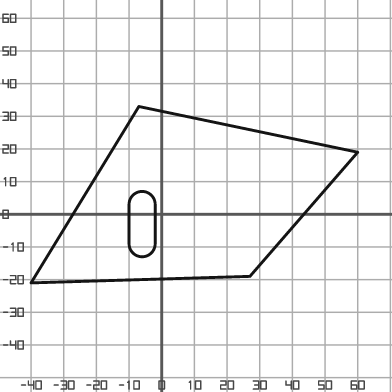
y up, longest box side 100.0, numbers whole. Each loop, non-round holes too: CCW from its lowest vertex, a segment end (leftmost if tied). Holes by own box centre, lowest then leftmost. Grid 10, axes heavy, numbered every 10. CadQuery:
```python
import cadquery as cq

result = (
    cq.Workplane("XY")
    .moveTo(-40.0, -21.0)
    .lineTo(27.0, -19.0)
    .lineTo(60.0, 19.0)
    .lineTo(-7.0, 33.0)
    .close()
    .moveTo(-10.0, -9.0)
    .threePointArc((-6.0, -13.0), (-2.0, -9.0))
    .lineTo(-2.0, 3.0)
    .threePointArc((-6.0, 7.0), (-10.0, 3.0))
    .close()
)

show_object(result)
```